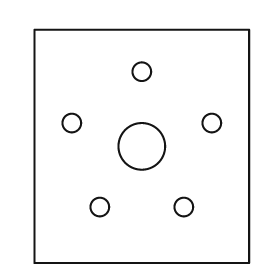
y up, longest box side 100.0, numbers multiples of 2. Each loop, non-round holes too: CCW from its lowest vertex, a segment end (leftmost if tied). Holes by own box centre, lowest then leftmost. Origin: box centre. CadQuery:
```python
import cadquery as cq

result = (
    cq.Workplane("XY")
    .moveTo(-46.0, -50.0)
    .lineTo(46.0, -50.0)
    .lineTo(46.0, 50.0)
    .lineTo(-46.0, 50.0)
    .close()
    .moveTo(-18.0, -26.0)
    .circle(4.0)
    .moveTo(18.0, -26.0)
    .circle(4.0)
    .moveTo(0.0, 0.0)
    .circle(10.0)
    .moveTo(-30.0, 10.0)
    .circle(4.0)
    .moveTo(30.0, 10.0)
    .circle(4.0)
    .moveTo(0.0, 32.0)
    .circle(4.0)
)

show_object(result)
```